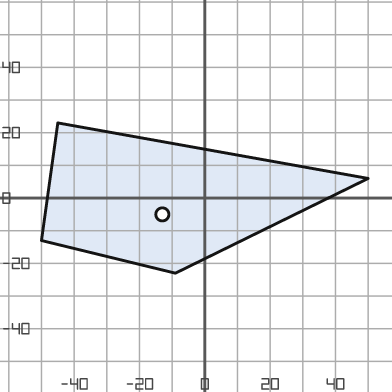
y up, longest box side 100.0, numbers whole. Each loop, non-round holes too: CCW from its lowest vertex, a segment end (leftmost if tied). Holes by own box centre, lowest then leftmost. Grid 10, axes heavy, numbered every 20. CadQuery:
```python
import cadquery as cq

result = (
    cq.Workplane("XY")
    .moveTo(-9.0, -23.0)
    .lineTo(50.0, 6.0)
    .lineTo(-45.0, 23.0)
    .lineTo(-50.0, -13.0)
    .close()
    .moveTo(-13.0, -5.0)
    .circle(2.0)
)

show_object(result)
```